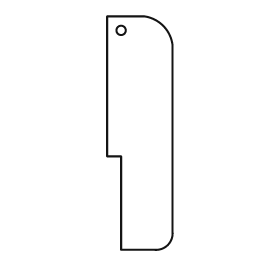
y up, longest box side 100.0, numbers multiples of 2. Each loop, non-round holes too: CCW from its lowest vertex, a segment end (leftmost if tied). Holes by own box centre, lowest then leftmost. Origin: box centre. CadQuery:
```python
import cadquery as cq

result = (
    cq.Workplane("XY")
    .moveTo(-8.0, -50.0)
    .lineTo(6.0, -50.0)
    .threePointArc((12.0, -48.0), (14.0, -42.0))
    .lineTo(14.0, 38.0)
    .threePointArc((10.0, 46.0), (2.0, 50.0))
    .lineTo(-14.0, 50.0)
    .lineTo(-14.0, -10.0)
    .lineTo(-8.0, -10.0)
    .close()
    .moveTo(-8.0, 44.0)
    .circle(2.0)
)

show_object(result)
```